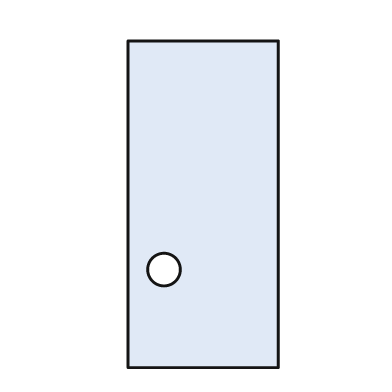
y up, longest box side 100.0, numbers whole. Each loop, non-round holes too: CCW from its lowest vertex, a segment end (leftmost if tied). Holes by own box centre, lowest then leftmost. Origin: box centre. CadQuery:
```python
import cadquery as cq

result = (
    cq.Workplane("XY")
    .moveTo(-23.0, -50.0)
    .lineTo(23.0, -50.0)
    .lineTo(23.0, 50.0)
    .lineTo(-23.0, 50.0)
    .close()
    .moveTo(-12.0, -20.0)
    .circle(5.0)
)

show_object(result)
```